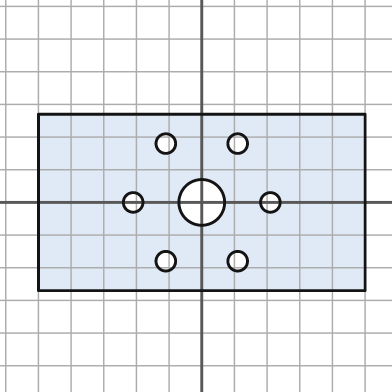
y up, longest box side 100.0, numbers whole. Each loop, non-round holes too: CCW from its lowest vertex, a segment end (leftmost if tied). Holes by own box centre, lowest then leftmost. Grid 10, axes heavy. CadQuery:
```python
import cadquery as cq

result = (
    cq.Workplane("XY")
    .moveTo(-50.0, -27.0)
    .lineTo(50.0, -27.0)
    .lineTo(50.0, 27.0)
    .lineTo(-50.0, 27.0)
    .close()
    .moveTo(-11.0, -18.0)
    .circle(3.0)
    .moveTo(11.0, -18.0)
    .circle(3.0)
    .moveTo(-21.0, 0.0)
    .circle(3.0)
    .moveTo(0.0, 0.0)
    .circle(7.0)
    .moveTo(21.0, 0.0)
    .circle(3.0)
    .moveTo(-11.0, 18.0)
    .circle(3.0)
    .moveTo(11.0, 18.0)
    .circle(3.0)
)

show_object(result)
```